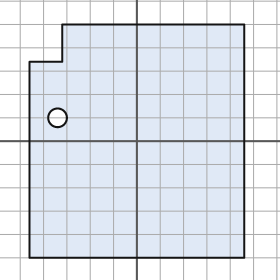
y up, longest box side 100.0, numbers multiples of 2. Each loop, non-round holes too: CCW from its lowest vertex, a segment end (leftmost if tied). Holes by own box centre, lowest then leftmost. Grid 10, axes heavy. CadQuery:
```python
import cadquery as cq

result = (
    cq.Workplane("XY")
    .moveTo(-46.0, -50.0)
    .lineTo(46.0, -50.0)
    .lineTo(46.0, 50.0)
    .lineTo(-32.0, 50.0)
    .lineTo(-32.0, 34.0)
    .lineTo(-46.0, 34.0)
    .close()
    .moveTo(-34.0, 10.0)
    .circle(4.0)
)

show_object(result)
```